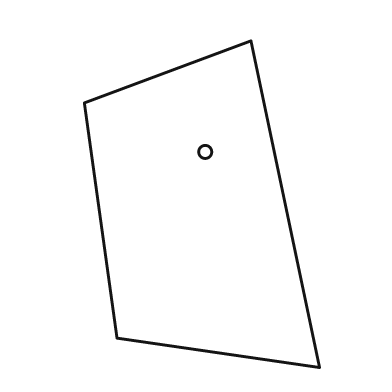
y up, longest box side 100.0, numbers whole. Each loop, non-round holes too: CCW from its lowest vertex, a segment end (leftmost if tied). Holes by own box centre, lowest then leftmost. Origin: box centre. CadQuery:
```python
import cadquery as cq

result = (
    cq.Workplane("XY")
    .moveTo(36.0, -50.0)
    .lineTo(15.0, 50.0)
    .lineTo(-36.0, 31.0)
    .lineTo(-26.0, -41.0)
    .close()
    .moveTo(1.0, 16.0)
    .circle(2.0)
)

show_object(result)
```